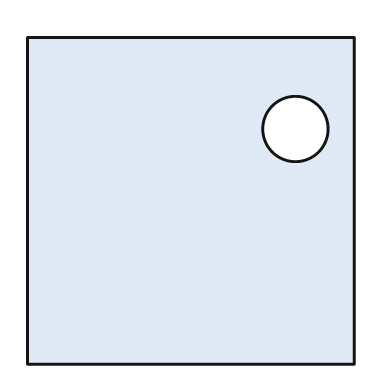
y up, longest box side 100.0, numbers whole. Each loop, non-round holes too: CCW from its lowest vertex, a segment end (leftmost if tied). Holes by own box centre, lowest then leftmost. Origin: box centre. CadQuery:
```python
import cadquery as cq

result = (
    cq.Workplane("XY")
    .moveTo(-50.0, -50.0)
    .lineTo(50.0, -50.0)
    .lineTo(50.0, 50.0)
    .lineTo(-50.0, 50.0)
    .close()
    .moveTo(32.0, 22.0)
    .circle(10.0)
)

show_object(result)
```